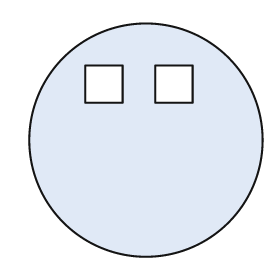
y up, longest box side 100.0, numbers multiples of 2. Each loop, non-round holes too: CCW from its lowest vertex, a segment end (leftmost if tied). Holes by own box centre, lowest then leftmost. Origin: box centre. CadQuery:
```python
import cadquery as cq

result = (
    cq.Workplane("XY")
    .moveTo(0.0, 0.0)
    .circle(50.0)
    .moveTo(-26.0, 16.0)
    .lineTo(-10.0, 16.0)
    .lineTo(-10.0, 32.0)
    .lineTo(-26.0, 32.0)
    .close()
    .moveTo(4.0, 16.0)
    .lineTo(20.0, 16.0)
    .lineTo(20.0, 32.0)
    .lineTo(4.0, 32.0)
    .close()
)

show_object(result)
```